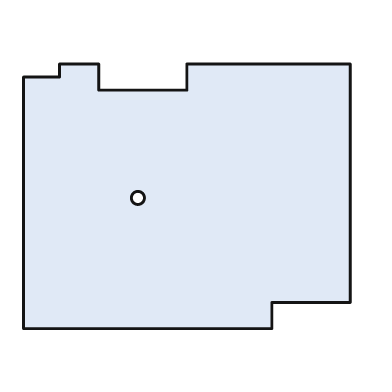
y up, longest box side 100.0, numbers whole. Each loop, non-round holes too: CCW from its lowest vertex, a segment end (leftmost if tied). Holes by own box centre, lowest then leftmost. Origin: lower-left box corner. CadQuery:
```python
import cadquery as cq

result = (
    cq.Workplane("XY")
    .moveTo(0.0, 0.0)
    .lineTo(76.0, 0.0)
    .lineTo(76.0, 8.0)
    .lineTo(100.0, 8.0)
    .lineTo(100.0, 81.0)
    .lineTo(50.0, 81.0)
    .lineTo(50.0, 73.0)
    .lineTo(23.0, 73.0)
    .lineTo(23.0, 81.0)
    .lineTo(11.0, 81.0)
    .lineTo(11.0, 77.0)
    .lineTo(0.0, 77.0)
    .close()
    .moveTo(35.0, 40.0)
    .circle(2.0)
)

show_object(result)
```